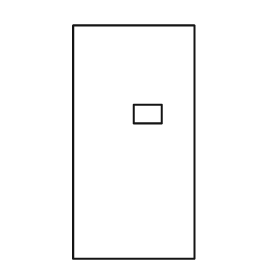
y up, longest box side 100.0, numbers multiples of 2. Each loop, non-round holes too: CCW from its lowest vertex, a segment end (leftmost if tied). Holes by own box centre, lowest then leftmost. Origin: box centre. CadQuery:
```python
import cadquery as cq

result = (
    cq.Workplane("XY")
    .moveTo(-26.0, -50.0)
    .lineTo(26.0, -50.0)
    .lineTo(26.0, 50.0)
    .lineTo(-26.0, 50.0)
    .close()
    .moveTo(0.0, 8.0)
    .lineTo(12.0, 8.0)
    .lineTo(12.0, 16.0)
    .lineTo(0.0, 16.0)
    .close()
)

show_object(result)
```